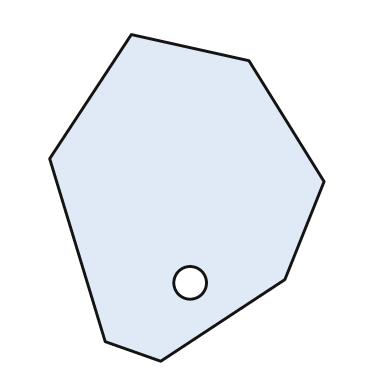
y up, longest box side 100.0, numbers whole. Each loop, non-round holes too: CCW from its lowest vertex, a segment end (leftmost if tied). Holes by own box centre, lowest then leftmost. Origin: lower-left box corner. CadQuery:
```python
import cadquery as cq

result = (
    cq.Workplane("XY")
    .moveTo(34.0, 0.0)
    .lineTo(72.0, 25.0)
    .lineTo(84.0, 55.0)
    .lineTo(61.0, 92.0)
    .lineTo(25.0, 100.0)
    .lineTo(0.0, 62.0)
    .lineTo(17.0, 6.0)
    .close()
    .moveTo(43.0, 24.0)
    .circle(5.0)
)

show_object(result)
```